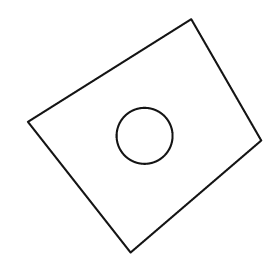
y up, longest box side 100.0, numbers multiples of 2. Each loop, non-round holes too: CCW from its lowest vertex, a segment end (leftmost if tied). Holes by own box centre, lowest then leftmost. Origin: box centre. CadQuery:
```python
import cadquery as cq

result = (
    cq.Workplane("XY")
    .moveTo(-6.0, -50.0)
    .lineTo(50.0, -2.0)
    .lineTo(20.0, 50.0)
    .lineTo(-50.0, 6.0)
    .close()
    .moveTo(0.0, 0.0)
    .circle(12.0)
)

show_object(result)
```